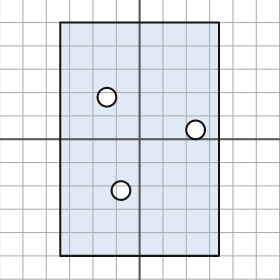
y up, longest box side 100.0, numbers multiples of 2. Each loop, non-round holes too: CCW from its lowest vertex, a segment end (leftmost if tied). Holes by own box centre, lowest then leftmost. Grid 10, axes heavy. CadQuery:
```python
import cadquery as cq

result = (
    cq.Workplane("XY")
    .moveTo(-34.0, -50.0)
    .lineTo(34.0, -50.0)
    .lineTo(34.0, 50.0)
    .lineTo(-34.0, 50.0)
    .close()
    .moveTo(-8.0, -22.0)
    .circle(4.0)
    .moveTo(24.0, 4.0)
    .circle(4.0)
    .moveTo(-14.0, 18.0)
    .circle(4.0)
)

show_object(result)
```